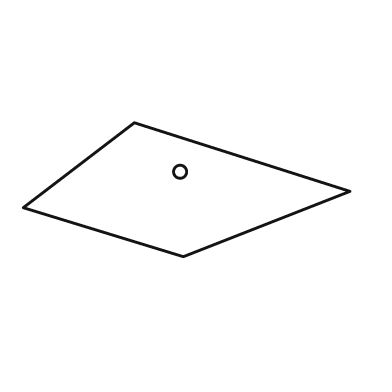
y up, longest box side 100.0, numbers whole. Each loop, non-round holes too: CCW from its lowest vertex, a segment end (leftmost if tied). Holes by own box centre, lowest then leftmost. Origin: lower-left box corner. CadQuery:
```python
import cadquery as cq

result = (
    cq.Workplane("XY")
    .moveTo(49.0, 0.0)
    .lineTo(100.0, 20.0)
    .lineTo(34.0, 41.0)
    .lineTo(0.0, 15.0)
    .close()
    .moveTo(48.0, 26.0)
    .circle(2.0)
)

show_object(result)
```